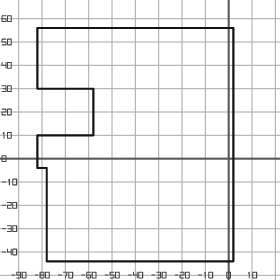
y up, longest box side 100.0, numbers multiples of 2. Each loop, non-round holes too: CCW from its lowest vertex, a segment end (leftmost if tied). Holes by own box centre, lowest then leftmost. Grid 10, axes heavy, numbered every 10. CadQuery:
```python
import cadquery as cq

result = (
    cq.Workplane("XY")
    .moveTo(-78.0, -44.0)
    .lineTo(2.0, -44.0)
    .lineTo(2.0, 56.0)
    .lineTo(-82.0, 56.0)
    .lineTo(-82.0, 30.0)
    .lineTo(-58.0, 30.0)
    .lineTo(-58.0, 10.0)
    .lineTo(-82.0, 10.0)
    .lineTo(-82.0, -4.0)
    .lineTo(-78.0, -4.0)
    .close()
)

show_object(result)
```